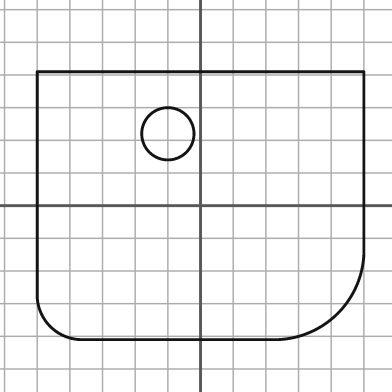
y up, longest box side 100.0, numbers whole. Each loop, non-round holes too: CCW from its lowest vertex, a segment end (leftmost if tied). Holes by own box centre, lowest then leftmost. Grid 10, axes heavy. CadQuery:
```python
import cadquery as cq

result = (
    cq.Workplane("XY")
    .moveTo(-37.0, -41.0)
    .lineTo(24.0, -41.0)
    .threePointArc((42.0, -33.0), (50.0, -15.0))
    .lineTo(50.0, 41.0)
    .lineTo(-50.0, 41.0)
    .lineTo(-50.0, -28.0)
    .threePointArc((-46.0, -37.0), (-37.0, -41.0))
    .close()
    .moveTo(-10.0, 22.0)
    .circle(8.0)
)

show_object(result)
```